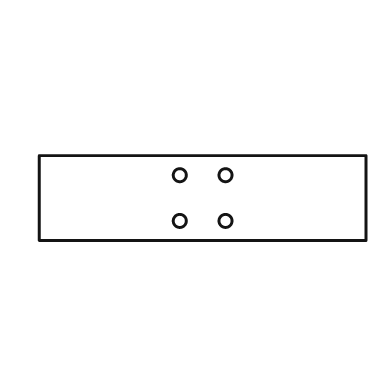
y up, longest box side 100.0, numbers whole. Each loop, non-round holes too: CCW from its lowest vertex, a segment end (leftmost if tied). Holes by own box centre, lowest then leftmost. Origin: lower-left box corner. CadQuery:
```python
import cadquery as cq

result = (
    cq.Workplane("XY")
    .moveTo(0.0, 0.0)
    .lineTo(100.0, 0.0)
    .lineTo(100.0, 26.0)
    .lineTo(0.0, 26.0)
    .close()
    .moveTo(43.0, 6.0)
    .circle(2.0)
    .moveTo(57.0, 6.0)
    .circle(2.0)
    .moveTo(43.0, 20.0)
    .circle(2.0)
    .moveTo(57.0, 20.0)
    .circle(2.0)
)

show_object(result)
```